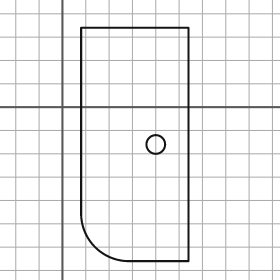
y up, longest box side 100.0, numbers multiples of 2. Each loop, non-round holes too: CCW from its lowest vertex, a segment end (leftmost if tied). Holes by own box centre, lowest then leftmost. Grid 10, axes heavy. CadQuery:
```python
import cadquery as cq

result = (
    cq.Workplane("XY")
    .moveTo(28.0, -66.0)
    .lineTo(54.0, -66.0)
    .lineTo(54.0, 34.0)
    .lineTo(8.0, 34.0)
    .lineTo(8.0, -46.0)
    .threePointArc((14.0, -60.0), (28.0, -66.0))
    .close()
    .moveTo(40.0, -16.0)
    .circle(4.0)
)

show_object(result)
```